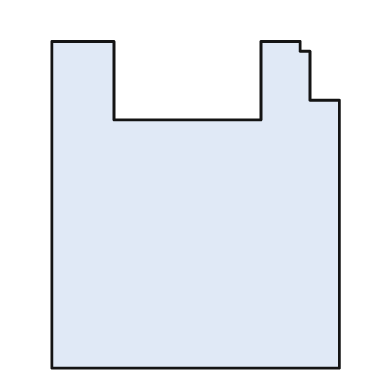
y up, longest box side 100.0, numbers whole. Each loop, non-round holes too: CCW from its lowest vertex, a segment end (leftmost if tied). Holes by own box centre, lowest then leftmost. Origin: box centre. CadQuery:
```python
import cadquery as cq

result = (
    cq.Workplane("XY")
    .moveTo(-44.0, -50.0)
    .lineTo(44.0, -50.0)
    .lineTo(44.0, 32.0)
    .lineTo(35.0, 32.0)
    .lineTo(35.0, 47.0)
    .lineTo(32.0, 47.0)
    .lineTo(32.0, 50.0)
    .lineTo(20.0, 50.0)
    .lineTo(20.0, 26.0)
    .lineTo(-25.0, 26.0)
    .lineTo(-25.0, 50.0)
    .lineTo(-44.0, 50.0)
    .close()
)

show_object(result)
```